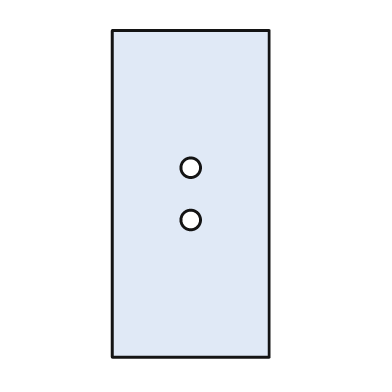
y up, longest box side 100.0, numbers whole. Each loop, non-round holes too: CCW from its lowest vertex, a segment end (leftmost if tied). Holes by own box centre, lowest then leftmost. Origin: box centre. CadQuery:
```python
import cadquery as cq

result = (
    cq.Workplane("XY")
    .moveTo(-24.0, -50.0)
    .lineTo(24.0, -50.0)
    .lineTo(24.0, 50.0)
    .lineTo(-24.0, 50.0)
    .close()
    .moveTo(0.0, -8.0)
    .circle(3.0)
    .moveTo(0.0, 8.0)
    .circle(3.0)
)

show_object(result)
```